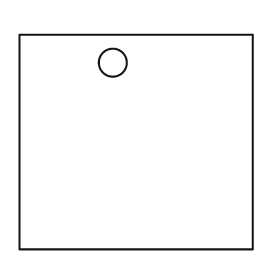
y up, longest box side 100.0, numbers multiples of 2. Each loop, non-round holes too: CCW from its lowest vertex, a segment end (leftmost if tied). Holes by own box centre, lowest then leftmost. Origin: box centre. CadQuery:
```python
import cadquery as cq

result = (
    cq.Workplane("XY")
    .moveTo(-50.0, -46.0)
    .lineTo(50.0, -46.0)
    .lineTo(50.0, 46.0)
    .lineTo(-50.0, 46.0)
    .close()
    .moveTo(-10.0, 34.0)
    .circle(6.0)
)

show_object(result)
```